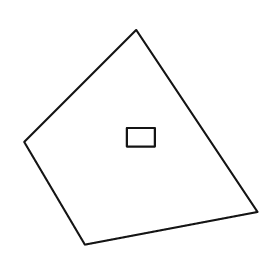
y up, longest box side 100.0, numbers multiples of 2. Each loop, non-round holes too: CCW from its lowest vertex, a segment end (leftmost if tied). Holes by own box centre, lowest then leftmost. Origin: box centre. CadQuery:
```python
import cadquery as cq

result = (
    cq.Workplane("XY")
    .moveTo(-24.0, -46.0)
    .lineTo(50.0, -32.0)
    .lineTo(-2.0, 46.0)
    .lineTo(-50.0, -2.0)
    .close()
    .moveTo(-6.0, -4.0)
    .lineTo(6.0, -4.0)
    .lineTo(6.0, 4.0)
    .lineTo(-6.0, 4.0)
    .close()
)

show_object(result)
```